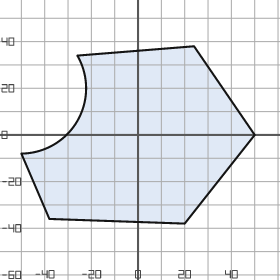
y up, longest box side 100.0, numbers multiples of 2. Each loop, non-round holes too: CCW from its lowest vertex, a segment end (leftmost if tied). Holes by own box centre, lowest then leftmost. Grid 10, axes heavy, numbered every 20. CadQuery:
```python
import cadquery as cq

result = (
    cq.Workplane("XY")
    .moveTo(20.0, -38.0)
    .lineTo(50.0, 0.0)
    .lineTo(24.0, 38.0)
    .lineTo(-26.0, 34.0)
    .threePointArc((-26.0, 6.0), (-50.0, -8.0))
    .lineTo(-38.0, -36.0)
    .close()
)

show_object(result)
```